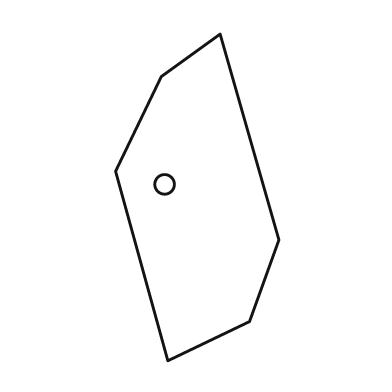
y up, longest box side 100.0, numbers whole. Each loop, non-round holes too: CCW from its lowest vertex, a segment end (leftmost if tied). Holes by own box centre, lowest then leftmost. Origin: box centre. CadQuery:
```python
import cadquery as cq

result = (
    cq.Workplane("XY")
    .moveTo(-9.0, -50.0)
    .lineTo(16.0, -38.0)
    .lineTo(25.0, -13.0)
    .lineTo(7.0, 50.0)
    .lineTo(-11.0, 37.0)
    .lineTo(-25.0, 8.0)
    .close()
    .moveTo(-10.0, 4.0)
    .circle(3.0)
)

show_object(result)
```